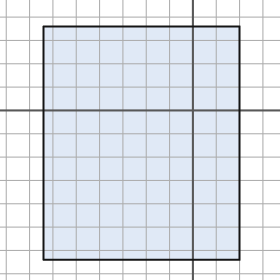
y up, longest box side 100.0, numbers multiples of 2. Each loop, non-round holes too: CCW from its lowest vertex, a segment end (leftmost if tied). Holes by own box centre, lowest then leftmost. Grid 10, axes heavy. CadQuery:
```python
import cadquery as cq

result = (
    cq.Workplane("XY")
    .moveTo(-64.0, -64.0)
    .lineTo(20.0, -64.0)
    .lineTo(20.0, 36.0)
    .lineTo(-64.0, 36.0)
    .close()
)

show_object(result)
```